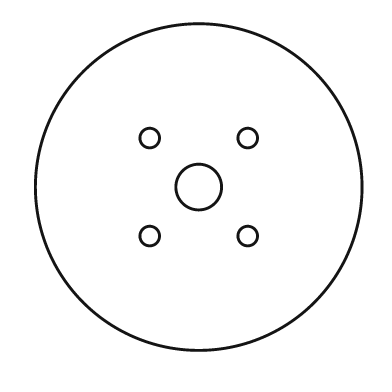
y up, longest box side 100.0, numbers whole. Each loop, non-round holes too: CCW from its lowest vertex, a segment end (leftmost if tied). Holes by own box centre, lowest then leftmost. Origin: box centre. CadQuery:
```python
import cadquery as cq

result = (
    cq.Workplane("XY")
    .moveTo(0.0, 0.0)
    .circle(50.0)
    .moveTo(-15.0, -15.0)
    .circle(3.0)
    .moveTo(15.0, -15.0)
    .circle(3.0)
    .moveTo(0.0, 0.0)
    .circle(7.0)
    .moveTo(-15.0, 15.0)
    .circle(3.0)
    .moveTo(15.0, 15.0)
    .circle(3.0)
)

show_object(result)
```